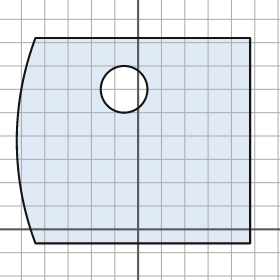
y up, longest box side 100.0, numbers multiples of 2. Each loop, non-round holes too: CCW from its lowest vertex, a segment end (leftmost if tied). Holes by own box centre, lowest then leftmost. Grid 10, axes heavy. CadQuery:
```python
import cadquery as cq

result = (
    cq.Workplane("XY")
    .moveTo(-44.0, -6.0)
    .lineTo(48.0, -6.0)
    .lineTo(48.0, 82.0)
    .lineTo(-44.0, 82.0)
    .threePointArc((-52.0, 38.0), (-44.0, -6.0))
    .close()
    .moveTo(-6.0, 60.0)
    .circle(10.0)
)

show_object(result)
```